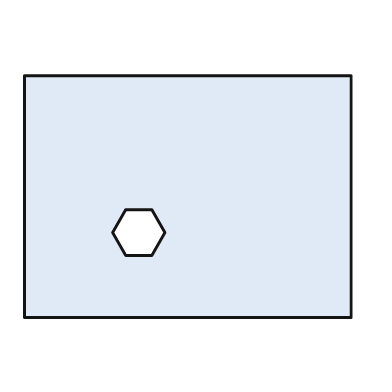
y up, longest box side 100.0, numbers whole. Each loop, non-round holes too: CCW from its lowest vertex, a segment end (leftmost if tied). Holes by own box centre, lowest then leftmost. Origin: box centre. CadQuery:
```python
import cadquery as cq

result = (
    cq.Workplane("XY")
    .moveTo(-50.0, -37.0)
    .lineTo(50.0, -37.0)
    .lineTo(50.0, 37.0)
    .lineTo(-50.0, 37.0)
    .close()
    .moveTo(-19.0, -18.0)
    .lineTo(-11.0, -18.0)
    .lineTo(-7.0, -11.0)
    .lineTo(-11.0, -4.0)
    .lineTo(-19.0, -4.0)
    .lineTo(-23.0, -11.0)
    .close()
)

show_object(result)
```